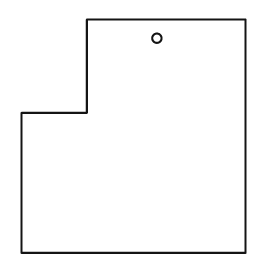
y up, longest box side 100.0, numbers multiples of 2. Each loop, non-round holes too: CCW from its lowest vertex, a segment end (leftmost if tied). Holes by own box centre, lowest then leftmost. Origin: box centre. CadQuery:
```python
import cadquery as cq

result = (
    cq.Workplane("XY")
    .moveTo(-48.0, -50.0)
    .lineTo(48.0, -50.0)
    .lineTo(48.0, 50.0)
    .lineTo(-20.0, 50.0)
    .lineTo(-20.0, 10.0)
    .lineTo(-48.0, 10.0)
    .close()
    .moveTo(10.0, 42.0)
    .circle(2.0)
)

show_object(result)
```